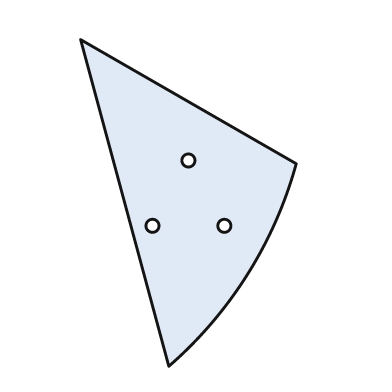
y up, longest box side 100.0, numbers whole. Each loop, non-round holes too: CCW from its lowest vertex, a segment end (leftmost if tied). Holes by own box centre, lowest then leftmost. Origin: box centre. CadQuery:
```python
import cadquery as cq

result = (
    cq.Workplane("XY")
    .moveTo(-6.0, -50.0)
    .threePointArc((18.0, -22.0), (33.0, 12.0))
    .lineTo(-33.0, 50.0)
    .close()
    .moveTo(-11.0, -7.0)
    .circle(2.0)
    .moveTo(11.0, -7.0)
    .circle(2.0)
    .moveTo(0.0, 13.0)
    .circle(2.0)
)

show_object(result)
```